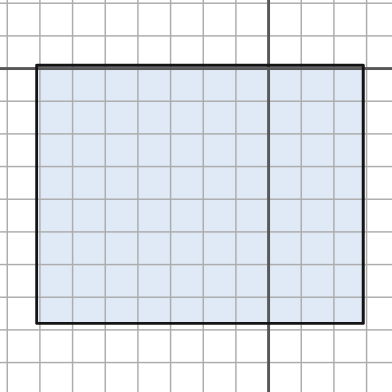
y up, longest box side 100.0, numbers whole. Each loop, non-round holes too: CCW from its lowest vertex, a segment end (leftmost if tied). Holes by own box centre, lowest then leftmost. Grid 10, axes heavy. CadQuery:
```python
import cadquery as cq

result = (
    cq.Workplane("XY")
    .moveTo(-71.0, -78.0)
    .lineTo(29.0, -78.0)
    .lineTo(29.0, 1.0)
    .lineTo(-71.0, 1.0)
    .close()
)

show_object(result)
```